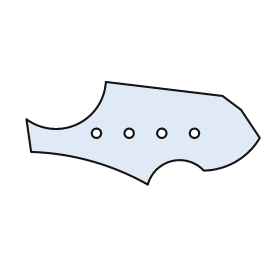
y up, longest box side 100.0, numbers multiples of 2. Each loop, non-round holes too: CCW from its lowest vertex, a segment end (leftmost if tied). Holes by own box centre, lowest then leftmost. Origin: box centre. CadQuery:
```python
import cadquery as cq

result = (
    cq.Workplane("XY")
    .moveTo(2.0, -22.0)
    .threePointArc((12.0, -12.0), (26.0, -16.0))
    .threePointArc((40.0, -12.0), (50.0, -2.0))
    .lineTo(42.0, 10.0)
    .lineTo(34.0, 16.0)
    .lineTo(-16.0, 22.0)
    .threePointArc((-28.0, 4.0), (-50.0, 6.0))
    .lineTo(-48.0, -8.0)
    .threePointArc((-22.0, -12.0), (2.0, -22.0))
    .close()
    .moveTo(-20.0, 0.0)
    .circle(2.0)
    .moveTo(-6.0, 0.0)
    .circle(2.0)
    .moveTo(8.0, 0.0)
    .circle(2.0)
    .moveTo(22.0, 0.0)
    .circle(2.0)
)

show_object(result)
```